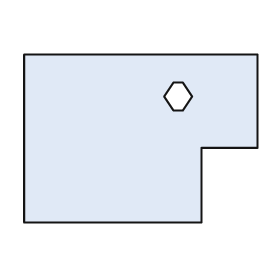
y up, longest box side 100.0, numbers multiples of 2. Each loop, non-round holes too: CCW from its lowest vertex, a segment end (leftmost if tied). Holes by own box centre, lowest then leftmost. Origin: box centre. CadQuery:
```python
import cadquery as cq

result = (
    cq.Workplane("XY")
    .moveTo(-50.0, -36.0)
    .lineTo(26.0, -36.0)
    .lineTo(26.0, -4.0)
    .lineTo(50.0, -4.0)
    .lineTo(50.0, 36.0)
    .lineTo(-50.0, 36.0)
    .close()
    .moveTo(14.0, 12.0)
    .lineTo(18.0, 12.0)
    .lineTo(22.0, 18.0)
    .lineTo(18.0, 24.0)
    .lineTo(14.0, 24.0)
    .lineTo(10.0, 18.0)
    .close()
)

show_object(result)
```